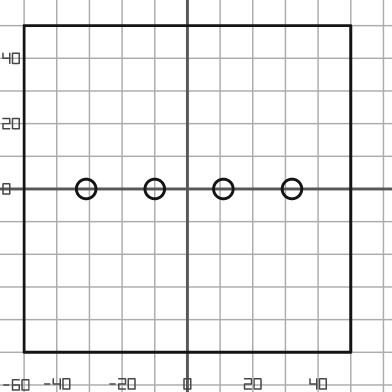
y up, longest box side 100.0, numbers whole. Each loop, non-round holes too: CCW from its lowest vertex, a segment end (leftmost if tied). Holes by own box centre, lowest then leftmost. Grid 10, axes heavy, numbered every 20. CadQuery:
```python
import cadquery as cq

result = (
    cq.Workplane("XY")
    .moveTo(-50.0, -50.0)
    .lineTo(50.0, -50.0)
    .lineTo(50.0, 50.0)
    .lineTo(-50.0, 50.0)
    .close()
    .moveTo(-31.0, 0.0)
    .circle(3.0)
    .moveTo(-10.0, 0.0)
    .circle(3.0)
    .moveTo(11.0, 0.0)
    .circle(3.0)
    .moveTo(32.0, 0.0)
    .circle(3.0)
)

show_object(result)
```